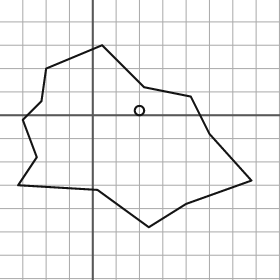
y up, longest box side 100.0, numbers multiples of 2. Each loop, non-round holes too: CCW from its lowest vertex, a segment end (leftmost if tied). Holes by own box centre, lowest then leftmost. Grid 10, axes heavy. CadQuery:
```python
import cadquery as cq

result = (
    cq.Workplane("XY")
    .moveTo(24.0, -48.0)
    .lineTo(40.0, -38.0)
    .lineTo(68.0, -28.0)
    .lineTo(50.0, -8.0)
    .lineTo(42.0, 8.0)
    .lineTo(22.0, 12.0)
    .lineTo(4.0, 30.0)
    .lineTo(-20.0, 20.0)
    .lineTo(-22.0, 6.0)
    .lineTo(-30.0, -2.0)
    .lineTo(-24.0, -18.0)
    .lineTo(-32.0, -30.0)
    .lineTo(2.0, -32.0)
    .close()
    .moveTo(20.0, 2.0)
    .circle(2.0)
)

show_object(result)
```